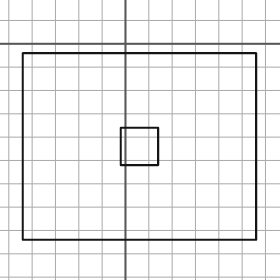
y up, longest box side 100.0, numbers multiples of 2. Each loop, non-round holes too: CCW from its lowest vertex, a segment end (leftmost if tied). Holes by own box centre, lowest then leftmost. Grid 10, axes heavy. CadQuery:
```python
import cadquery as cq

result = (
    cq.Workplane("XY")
    .moveTo(-44.0, -84.0)
    .lineTo(56.0, -84.0)
    .lineTo(56.0, -4.0)
    .lineTo(-44.0, -4.0)
    .close()
    .moveTo(-2.0, -52.0)
    .lineTo(14.0, -52.0)
    .lineTo(14.0, -36.0)
    .lineTo(-2.0, -36.0)
    .close()
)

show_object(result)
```